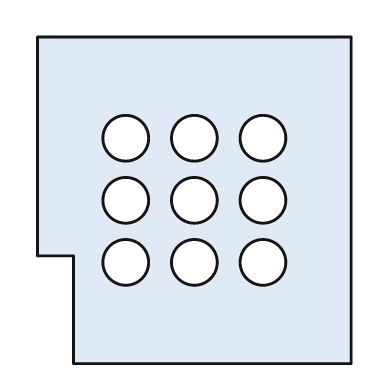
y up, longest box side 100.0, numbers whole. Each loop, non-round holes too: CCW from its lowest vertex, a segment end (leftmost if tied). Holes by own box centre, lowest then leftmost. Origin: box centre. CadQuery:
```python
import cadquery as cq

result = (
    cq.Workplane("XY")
    .moveTo(-37.0, -50.0)
    .lineTo(48.0, -50.0)
    .lineTo(48.0, 50.0)
    .lineTo(-48.0, 50.0)
    .lineTo(-48.0, -17.0)
    .lineTo(-37.0, -17.0)
    .close()
    .moveTo(-21.0, -19.0)
    .circle(7.0)
    .moveTo(0.0, -19.0)
    .circle(7.0)
    .moveTo(21.0, -19.0)
    .circle(7.0)
    .moveTo(-21.0, 0.0)
    .circle(7.0)
    .moveTo(0.0, 0.0)
    .circle(7.0)
    .moveTo(21.0, 0.0)
    .circle(7.0)
    .moveTo(-21.0, 19.0)
    .circle(7.0)
    .moveTo(0.0, 19.0)
    .circle(7.0)
    .moveTo(21.0, 19.0)
    .circle(7.0)
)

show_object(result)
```